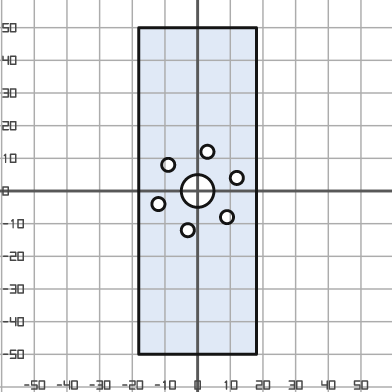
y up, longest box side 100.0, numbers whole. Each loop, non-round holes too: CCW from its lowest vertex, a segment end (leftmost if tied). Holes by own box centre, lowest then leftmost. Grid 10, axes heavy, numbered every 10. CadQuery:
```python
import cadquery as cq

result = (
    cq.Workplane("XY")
    .moveTo(-18.0, -50.0)
    .lineTo(18.0, -50.0)
    .lineTo(18.0, 50.0)
    .lineTo(-18.0, 50.0)
    .close()
    .moveTo(-3.0, -12.0)
    .circle(2.0)
    .moveTo(9.0, -8.0)
    .circle(2.0)
    .moveTo(-12.0, -4.0)
    .circle(2.0)
    .moveTo(0.0, 0.0)
    .circle(5.0)
    .moveTo(12.0, 4.0)
    .circle(2.0)
    .moveTo(-9.0, 8.0)
    .circle(2.0)
    .moveTo(3.0, 12.0)
    .circle(2.0)
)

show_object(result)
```